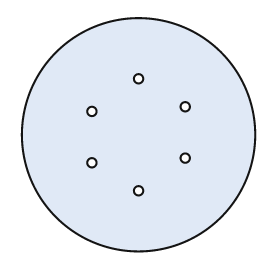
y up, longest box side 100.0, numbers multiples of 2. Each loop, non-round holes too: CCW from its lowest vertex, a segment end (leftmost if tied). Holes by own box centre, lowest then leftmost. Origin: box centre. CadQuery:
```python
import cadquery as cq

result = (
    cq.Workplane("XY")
    .moveTo(0.0, 0.0)
    .circle(50.0)
    .moveTo(0.0, -24.0)
    .circle(2.0)
    .moveTo(-20.0, -12.0)
    .circle(2.0)
    .moveTo(20.0, -10.0)
    .circle(2.0)
    .moveTo(-20.0, 10.0)
    .circle(2.0)
    .moveTo(20.0, 12.0)
    .circle(2.0)
    .moveTo(0.0, 24.0)
    .circle(2.0)
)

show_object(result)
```